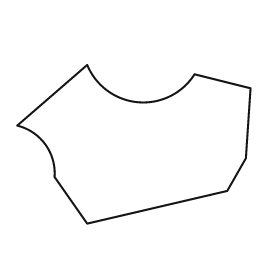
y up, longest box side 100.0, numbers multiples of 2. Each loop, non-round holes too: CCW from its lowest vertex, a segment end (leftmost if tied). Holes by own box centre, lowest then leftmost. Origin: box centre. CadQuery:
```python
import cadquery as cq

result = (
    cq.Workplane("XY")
    .moveTo(-20.0, -34.0)
    .lineTo(40.0, -20.0)
    .lineTo(48.0, -6.0)
    .lineTo(50.0, 24.0)
    .lineTo(26.0, 30.0)
    .threePointArc((2.0, 18.0), (-20.0, 34.0))
    .lineTo(-50.0, 8.0)
    .threePointArc((-38.0, 0.0), (-34.0, -14.0))
    .close()
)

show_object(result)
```